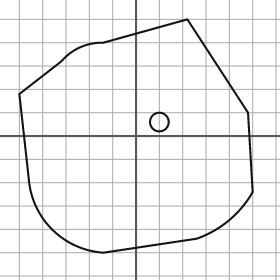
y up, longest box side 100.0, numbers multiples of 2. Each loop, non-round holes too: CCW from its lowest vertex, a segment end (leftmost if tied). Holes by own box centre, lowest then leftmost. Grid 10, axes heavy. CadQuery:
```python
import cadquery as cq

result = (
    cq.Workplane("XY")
    .moveTo(-14.0, -50.0)
    .lineTo(26.0, -44.0)
    .threePointArc((40.0, -36.0), (50.0, -24.0))
    .lineTo(48.0, 10.0)
    .lineTo(22.0, 50.0)
    .lineTo(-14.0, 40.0)
    .threePointArc((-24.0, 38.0), (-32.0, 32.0))
    .lineTo(-50.0, 18.0)
    .lineTo(-46.0, -18.0)
    .threePointArc((-36.0, -40.0), (-14.0, -50.0))
    .close()
    .moveTo(10.0, 6.0)
    .circle(4.0)
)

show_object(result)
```